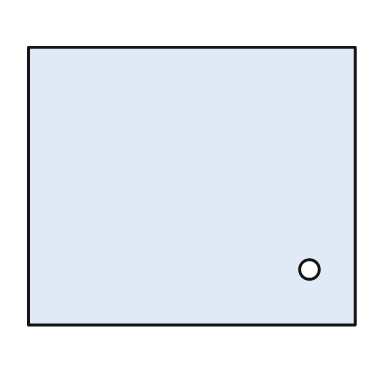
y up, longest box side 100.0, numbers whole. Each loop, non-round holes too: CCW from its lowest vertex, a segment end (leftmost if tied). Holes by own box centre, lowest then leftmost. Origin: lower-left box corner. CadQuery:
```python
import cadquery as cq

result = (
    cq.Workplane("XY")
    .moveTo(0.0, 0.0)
    .lineTo(100.0, 0.0)
    .lineTo(100.0, 85.0)
    .lineTo(0.0, 85.0)
    .close()
    .moveTo(86.0, 17.0)
    .circle(3.0)
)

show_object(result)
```